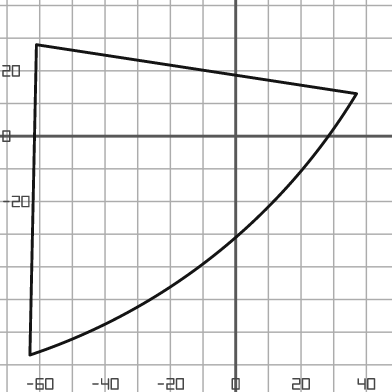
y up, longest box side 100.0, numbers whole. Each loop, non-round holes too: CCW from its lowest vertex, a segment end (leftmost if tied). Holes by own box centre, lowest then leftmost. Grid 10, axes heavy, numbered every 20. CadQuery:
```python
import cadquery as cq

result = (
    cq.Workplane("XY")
    .moveTo(-63.0, -67.0)
    .threePointArc((-6.0, -36.0), (37.0, 13.0))
    .lineTo(-61.0, 28.0)
    .close()
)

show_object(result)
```